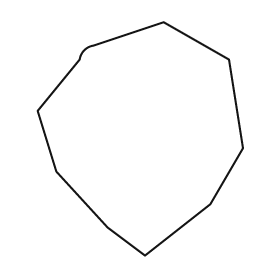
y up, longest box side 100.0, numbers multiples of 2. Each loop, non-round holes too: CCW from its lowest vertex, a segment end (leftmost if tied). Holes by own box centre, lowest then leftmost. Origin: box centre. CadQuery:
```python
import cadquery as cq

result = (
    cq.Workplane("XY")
    .moveTo(2.0, -50.0)
    .lineTo(30.0, -28.0)
    .lineTo(44.0, -4.0)
    .lineTo(38.0, 34.0)
    .lineTo(10.0, 50.0)
    .lineTo(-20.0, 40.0)
    .threePointArc((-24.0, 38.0), (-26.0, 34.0))
    .lineTo(-44.0, 12.0)
    .lineTo(-36.0, -14.0)
    .lineTo(-14.0, -38.0)
    .close()
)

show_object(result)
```